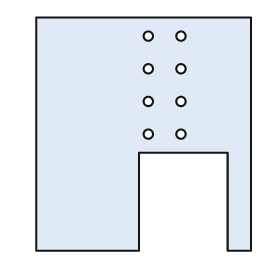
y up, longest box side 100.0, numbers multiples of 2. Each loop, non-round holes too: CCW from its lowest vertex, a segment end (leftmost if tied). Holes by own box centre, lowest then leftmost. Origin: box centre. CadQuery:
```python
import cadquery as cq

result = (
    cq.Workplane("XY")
    .moveTo(-46.0, -50.0)
    .lineTo(-2.0, -50.0)
    .lineTo(-2.0, -8.0)
    .lineTo(36.0, -8.0)
    .lineTo(36.0, -50.0)
    .lineTo(46.0, -50.0)
    .lineTo(46.0, 50.0)
    .lineTo(-46.0, 50.0)
    .close()
    .moveTo(2.0, 0.0)
    .circle(2.0)
    .moveTo(16.0, 0.0)
    .circle(2.0)
    .moveTo(2.0, 14.0)
    .circle(2.0)
    .moveTo(16.0, 14.0)
    .circle(2.0)
    .moveTo(2.0, 28.0)
    .circle(2.0)
    .moveTo(16.0, 28.0)
    .circle(2.0)
    .moveTo(2.0, 42.0)
    .circle(2.0)
    .moveTo(16.0, 42.0)
    .circle(2.0)
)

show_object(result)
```